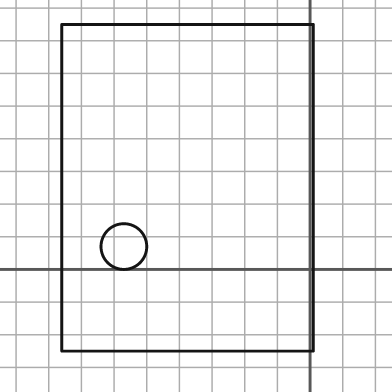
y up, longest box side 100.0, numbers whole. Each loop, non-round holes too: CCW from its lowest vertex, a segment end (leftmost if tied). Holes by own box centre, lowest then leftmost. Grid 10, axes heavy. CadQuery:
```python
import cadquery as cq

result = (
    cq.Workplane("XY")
    .moveTo(-76.0, -25.0)
    .lineTo(1.0, -25.0)
    .lineTo(1.0, 75.0)
    .lineTo(-76.0, 75.0)
    .close()
    .moveTo(-57.0, 7.0)
    .circle(7.0)
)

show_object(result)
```